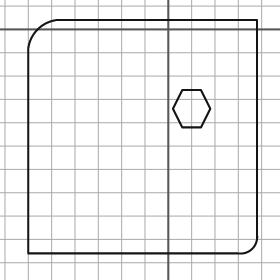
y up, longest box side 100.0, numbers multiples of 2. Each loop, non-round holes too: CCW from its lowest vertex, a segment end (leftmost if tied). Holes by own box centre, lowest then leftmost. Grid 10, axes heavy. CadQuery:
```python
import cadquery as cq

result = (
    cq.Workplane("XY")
    .moveTo(-60.0, -96.0)
    .lineTo(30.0, -96.0)
    .threePointArc((36.0, -94.0), (38.0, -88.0))
    .lineTo(38.0, 4.0)
    .lineTo(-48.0, 4.0)
    .threePointArc((-56.0, 0.0), (-60.0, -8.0))
    .close()
    .moveTo(6.0, -42.0)
    .lineTo(14.0, -42.0)
    .lineTo(18.0, -34.0)
    .lineTo(14.0, -26.0)
    .lineTo(6.0, -26.0)
    .lineTo(2.0, -34.0)
    .close()
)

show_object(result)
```